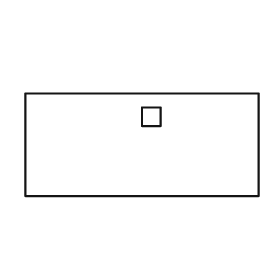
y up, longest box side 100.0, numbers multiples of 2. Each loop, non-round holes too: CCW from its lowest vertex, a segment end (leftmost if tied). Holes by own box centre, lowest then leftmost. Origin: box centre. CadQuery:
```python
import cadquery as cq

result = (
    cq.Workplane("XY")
    .moveTo(-50.0, -22.0)
    .lineTo(50.0, -22.0)
    .lineTo(50.0, 22.0)
    .lineTo(-50.0, 22.0)
    .close()
    .moveTo(0.0, 8.0)
    .lineTo(8.0, 8.0)
    .lineTo(8.0, 16.0)
    .lineTo(0.0, 16.0)
    .close()
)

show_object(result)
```